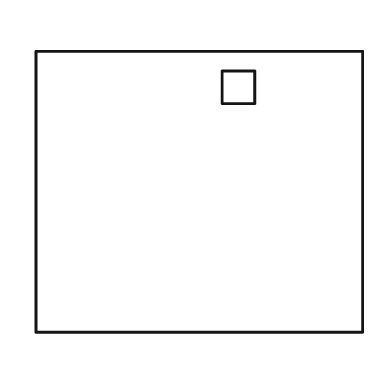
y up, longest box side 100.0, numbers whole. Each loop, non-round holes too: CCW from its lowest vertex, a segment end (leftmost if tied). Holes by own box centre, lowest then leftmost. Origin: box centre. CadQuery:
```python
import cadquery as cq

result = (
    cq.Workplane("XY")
    .moveTo(-50.0, -43.0)
    .lineTo(50.0, -43.0)
    .lineTo(50.0, 43.0)
    .lineTo(-50.0, 43.0)
    .close()
    .moveTo(7.0, 27.0)
    .lineTo(17.0, 27.0)
    .lineTo(17.0, 37.0)
    .lineTo(7.0, 37.0)
    .close()
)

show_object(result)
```